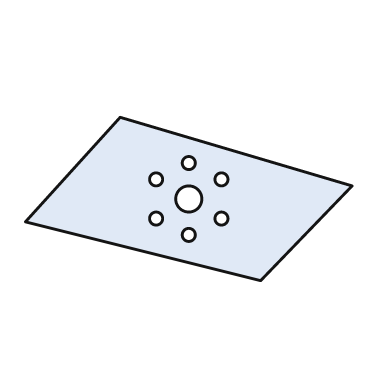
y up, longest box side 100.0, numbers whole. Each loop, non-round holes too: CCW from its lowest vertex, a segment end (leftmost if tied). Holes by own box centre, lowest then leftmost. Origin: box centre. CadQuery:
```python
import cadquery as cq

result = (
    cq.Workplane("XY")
    .moveTo(22.0, -25.0)
    .lineTo(50.0, 4.0)
    .lineTo(-21.0, 25.0)
    .lineTo(-50.0, -7.0)
    .close()
    .moveTo(0.0, -11.0)
    .circle(2.0)
    .moveTo(-10.0, -6.0)
    .circle(2.0)
    .moveTo(10.0, -6.0)
    .circle(2.0)
    .moveTo(0.0, 0.0)
    .circle(4.0)
    .moveTo(-10.0, 6.0)
    .circle(2.0)
    .moveTo(10.0, 6.0)
    .circle(2.0)
    .moveTo(0.0, 11.0)
    .circle(2.0)
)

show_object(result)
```